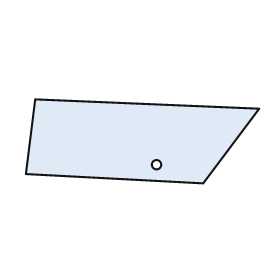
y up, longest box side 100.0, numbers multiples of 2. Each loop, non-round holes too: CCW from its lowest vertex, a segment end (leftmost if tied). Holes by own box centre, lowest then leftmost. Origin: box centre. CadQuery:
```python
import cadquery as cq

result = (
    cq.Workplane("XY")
    .moveTo(26.0, -18.0)
    .lineTo(50.0, 14.0)
    .lineTo(-46.0, 18.0)
    .lineTo(-50.0, -14.0)
    .close()
    .moveTo(6.0, -10.0)
    .circle(2.0)
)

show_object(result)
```